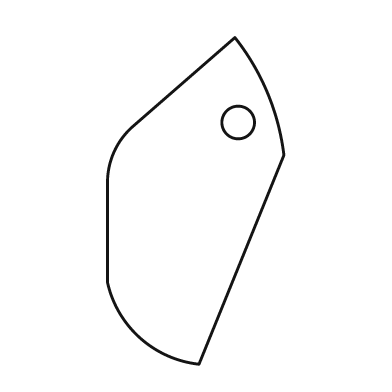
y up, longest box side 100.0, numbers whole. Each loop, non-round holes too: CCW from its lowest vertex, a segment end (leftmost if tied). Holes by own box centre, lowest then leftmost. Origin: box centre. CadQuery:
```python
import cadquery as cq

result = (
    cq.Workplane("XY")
    .moveTo(1.0, -50.0)
    .lineTo(27.0, 14.0)
    .threePointArc((22.0, 33.0), (12.0, 50.0))
    .lineTo(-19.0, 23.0)
    .threePointArc((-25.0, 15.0), (-27.0, 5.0))
    .lineTo(-27.0, -25.0)
    .threePointArc((-17.0, -42.0), (1.0, -50.0))
    .close()
    .moveTo(13.0, 24.0)
    .circle(5.0)
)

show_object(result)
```